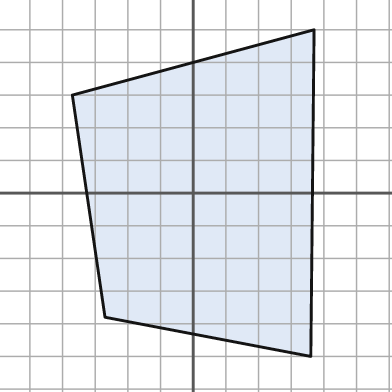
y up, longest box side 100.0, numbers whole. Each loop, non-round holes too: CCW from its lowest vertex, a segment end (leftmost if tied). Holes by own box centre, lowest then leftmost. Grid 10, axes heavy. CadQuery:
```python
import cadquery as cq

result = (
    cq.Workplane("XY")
    .moveTo(36.0, -50.0)
    .lineTo(37.0, 50.0)
    .lineTo(-37.0, 30.0)
    .lineTo(-27.0, -38.0)
    .close()
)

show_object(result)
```